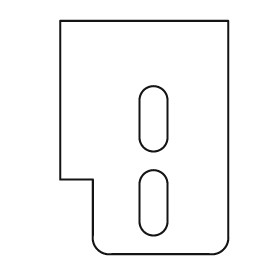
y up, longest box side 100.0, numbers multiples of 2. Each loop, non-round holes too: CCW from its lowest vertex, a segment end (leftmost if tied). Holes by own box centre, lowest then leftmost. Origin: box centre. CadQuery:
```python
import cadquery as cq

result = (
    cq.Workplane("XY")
    .moveTo(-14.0, -50.0)
    .lineTo(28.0, -50.0)
    .threePointArc((34.0, -48.0), (36.0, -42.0))
    .lineTo(36.0, 50.0)
    .lineTo(-36.0, 50.0)
    .lineTo(-36.0, -18.0)
    .lineTo(-22.0, -18.0)
    .lineTo(-22.0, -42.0)
    .threePointArc((-20.0, -48.0), (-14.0, -50.0))
    .close()
    .moveTo(-2.0, -36.0)
    .threePointArc((4.0, -42.0), (10.0, -36.0))
    .lineTo(10.0, -20.0)
    .threePointArc((4.0, -14.0), (-2.0, -20.0))
    .close()
    .moveTo(-2.0, 0.0)
    .threePointArc((4.0, -6.0), (10.0, 0.0))
    .lineTo(10.0, 16.0)
    .threePointArc((4.0, 22.0), (-2.0, 16.0))
    .close()
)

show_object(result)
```